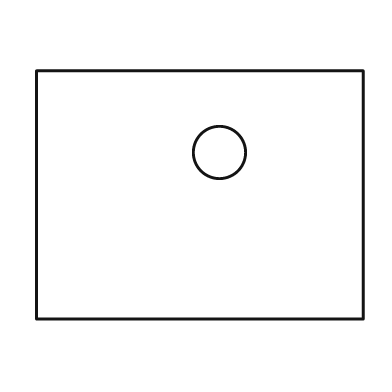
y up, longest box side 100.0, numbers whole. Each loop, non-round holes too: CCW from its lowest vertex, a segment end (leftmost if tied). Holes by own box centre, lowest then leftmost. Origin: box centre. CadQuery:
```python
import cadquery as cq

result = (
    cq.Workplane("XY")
    .moveTo(-50.0, -38.0)
    .lineTo(50.0, -38.0)
    .lineTo(50.0, 38.0)
    .lineTo(-50.0, 38.0)
    .close()
    .moveTo(6.0, 13.0)
    .circle(8.0)
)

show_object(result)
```